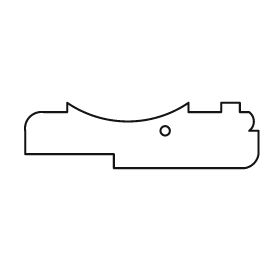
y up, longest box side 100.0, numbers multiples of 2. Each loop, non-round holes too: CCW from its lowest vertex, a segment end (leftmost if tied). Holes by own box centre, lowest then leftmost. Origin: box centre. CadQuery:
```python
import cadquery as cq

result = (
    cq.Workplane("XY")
    .moveTo(-12.0, -14.0)
    .lineTo(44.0, -14.0)
    .threePointArc((48.0, -12.0), (50.0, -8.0))
    .lineTo(50.0, 2.0)
    .lineTo(46.0, 2.0)
    .threePointArc((48.0, 6.0), (46.0, 10.0))
    .lineTo(42.0, 10.0)
    .lineTo(42.0, 14.0)
    .lineTo(34.0, 14.0)
    .lineTo(34.0, 10.0)
    .lineTo(20.0, 10.0)
    .lineTo(20.0, 14.0)
    .threePointArc((-6.0, 6.0), (-32.0, 14.0))
    .lineTo(-32.0, 10.0)
    .lineTo(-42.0, 10.0)
    .threePointArc((-48.0, 8.0), (-50.0, 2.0))
    .lineTo(-50.0, -8.0)
    .lineTo(-12.0, -8.0)
    .close()
    .moveTo(10.0, 2.0)
    .circle(2.0)
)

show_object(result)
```